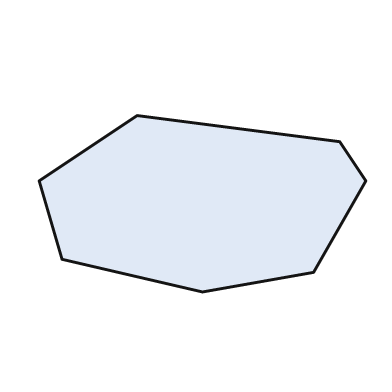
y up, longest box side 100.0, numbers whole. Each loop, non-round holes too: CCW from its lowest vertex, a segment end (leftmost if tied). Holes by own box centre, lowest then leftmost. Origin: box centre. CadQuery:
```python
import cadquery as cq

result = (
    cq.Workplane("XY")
    .moveTo(0.0, -27.0)
    .lineTo(34.0, -21.0)
    .lineTo(50.0, 7.0)
    .lineTo(42.0, 19.0)
    .lineTo(-20.0, 27.0)
    .lineTo(-50.0, 7.0)
    .lineTo(-43.0, -17.0)
    .close()
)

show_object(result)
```